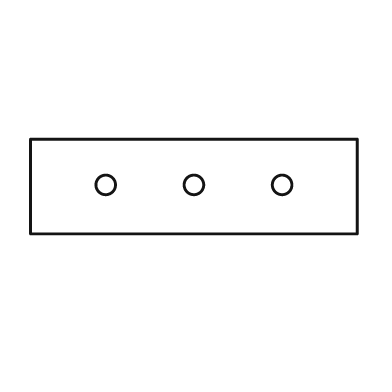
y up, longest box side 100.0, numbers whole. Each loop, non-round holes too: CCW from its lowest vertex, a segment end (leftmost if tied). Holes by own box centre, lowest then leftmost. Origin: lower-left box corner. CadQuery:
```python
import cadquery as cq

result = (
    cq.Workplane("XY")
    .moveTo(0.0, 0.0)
    .lineTo(100.0, 0.0)
    .lineTo(100.0, 29.0)
    .lineTo(0.0, 29.0)
    .close()
    .moveTo(23.0, 15.0)
    .circle(3.0)
    .moveTo(50.0, 15.0)
    .circle(3.0)
    .moveTo(77.0, 15.0)
    .circle(3.0)
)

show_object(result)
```